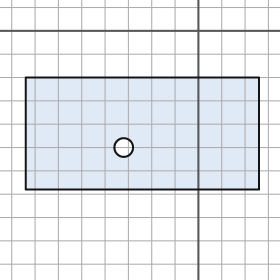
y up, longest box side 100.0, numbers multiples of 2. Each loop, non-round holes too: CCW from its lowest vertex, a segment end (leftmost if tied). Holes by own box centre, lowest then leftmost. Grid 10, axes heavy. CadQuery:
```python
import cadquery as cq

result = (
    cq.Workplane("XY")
    .moveTo(-74.0, -68.0)
    .lineTo(26.0, -68.0)
    .lineTo(26.0, -20.0)
    .lineTo(-74.0, -20.0)
    .close()
    .moveTo(-32.0, -50.0)
    .circle(4.0)
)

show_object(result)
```